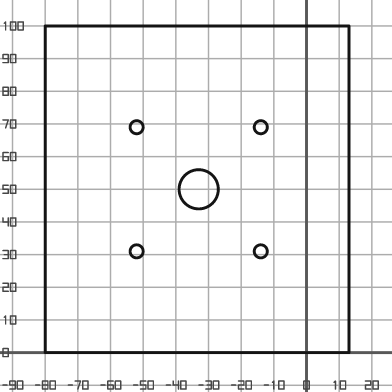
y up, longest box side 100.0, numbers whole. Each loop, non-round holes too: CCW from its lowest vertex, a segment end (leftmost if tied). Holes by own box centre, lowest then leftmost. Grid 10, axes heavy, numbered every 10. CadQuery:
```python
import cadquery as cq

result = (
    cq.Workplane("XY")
    .moveTo(-80.0, 0.0)
    .lineTo(13.0, 0.0)
    .lineTo(13.0, 100.0)
    .lineTo(-80.0, 100.0)
    .close()
    .moveTo(-52.0, 31.0)
    .circle(2.0)
    .moveTo(-14.0, 31.0)
    .circle(2.0)
    .moveTo(-33.0, 50.0)
    .circle(6.0)
    .moveTo(-52.0, 69.0)
    .circle(2.0)
    .moveTo(-14.0, 69.0)
    .circle(2.0)
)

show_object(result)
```